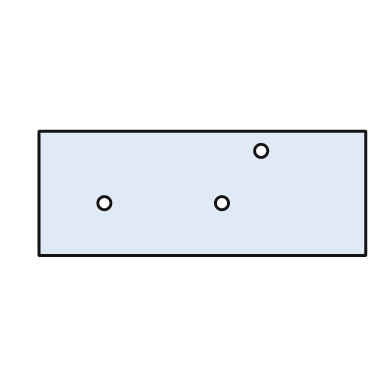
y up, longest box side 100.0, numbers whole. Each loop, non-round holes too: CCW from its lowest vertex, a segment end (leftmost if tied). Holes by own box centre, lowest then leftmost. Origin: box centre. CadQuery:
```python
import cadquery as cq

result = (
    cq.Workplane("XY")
    .moveTo(-50.0, -19.0)
    .lineTo(50.0, -19.0)
    .lineTo(50.0, 19.0)
    .lineTo(-50.0, 19.0)
    .close()
    .moveTo(-30.0, -3.0)
    .circle(2.0)
    .moveTo(6.0, -3.0)
    .circle(2.0)
    .moveTo(18.0, 13.0)
    .circle(2.0)
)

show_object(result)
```